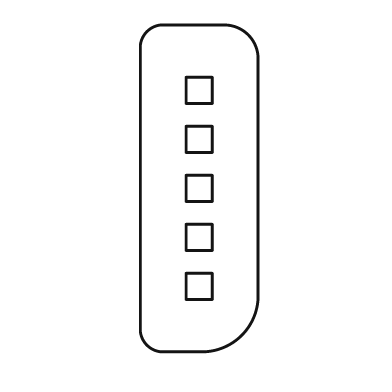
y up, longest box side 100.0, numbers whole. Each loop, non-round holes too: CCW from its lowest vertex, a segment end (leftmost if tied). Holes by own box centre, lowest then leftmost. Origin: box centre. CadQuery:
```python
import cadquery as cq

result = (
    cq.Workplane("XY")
    .moveTo(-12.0, -50.0)
    .lineTo(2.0, -50.0)
    .threePointArc((13.0, -45.0), (18.0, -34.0))
    .lineTo(18.0, 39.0)
    .threePointArc((15.0, 47.0), (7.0, 50.0))
    .lineTo(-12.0, 50.0)
    .threePointArc((-16.0, 48.0), (-18.0, 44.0))
    .lineTo(-18.0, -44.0)
    .threePointArc((-16.0, -48.0), (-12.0, -50.0))
    .close()
    .moveTo(-4.0, -34.0)
    .lineTo(4.0, -34.0)
    .lineTo(4.0, -26.0)
    .lineTo(-4.0, -26.0)
    .close()
    .moveTo(-4.0, -19.0)
    .lineTo(4.0, -19.0)
    .lineTo(4.0, -11.0)
    .lineTo(-4.0, -11.0)
    .close()
    .moveTo(-4.0, -4.0)
    .lineTo(4.0, -4.0)
    .lineTo(4.0, 4.0)
    .lineTo(-4.0, 4.0)
    .close()
    .moveTo(-4.0, 11.0)
    .lineTo(4.0, 11.0)
    .lineTo(4.0, 19.0)
    .lineTo(-4.0, 19.0)
    .close()
    .moveTo(-4.0, 26.0)
    .lineTo(4.0, 26.0)
    .lineTo(4.0, 34.0)
    .lineTo(-4.0, 34.0)
    .close()
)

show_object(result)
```